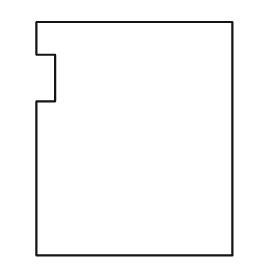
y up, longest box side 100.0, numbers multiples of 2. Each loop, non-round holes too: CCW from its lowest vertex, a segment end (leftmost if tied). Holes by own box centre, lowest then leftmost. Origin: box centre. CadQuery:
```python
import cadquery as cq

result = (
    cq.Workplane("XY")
    .moveTo(-42.0, -50.0)
    .lineTo(42.0, -50.0)
    .lineTo(42.0, 50.0)
    .lineTo(-42.0, 50.0)
    .lineTo(-42.0, 36.0)
    .lineTo(-34.0, 36.0)
    .lineTo(-34.0, 16.0)
    .lineTo(-42.0, 16.0)
    .close()
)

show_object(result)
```